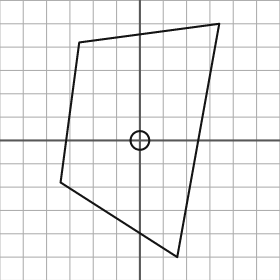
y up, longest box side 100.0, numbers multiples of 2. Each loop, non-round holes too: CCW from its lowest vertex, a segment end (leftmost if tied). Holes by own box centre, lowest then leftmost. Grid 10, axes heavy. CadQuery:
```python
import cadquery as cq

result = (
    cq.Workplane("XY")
    .moveTo(16.0, -50.0)
    .lineTo(34.0, 50.0)
    .lineTo(-26.0, 42.0)
    .lineTo(-34.0, -18.0)
    .close()
    .moveTo(0.0, 0.0)
    .circle(4.0)
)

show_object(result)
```